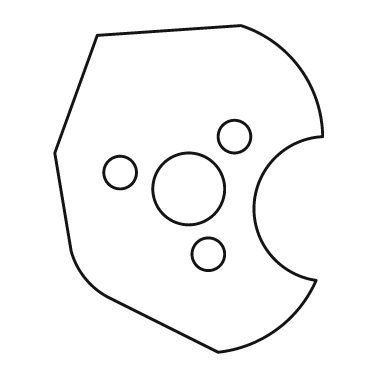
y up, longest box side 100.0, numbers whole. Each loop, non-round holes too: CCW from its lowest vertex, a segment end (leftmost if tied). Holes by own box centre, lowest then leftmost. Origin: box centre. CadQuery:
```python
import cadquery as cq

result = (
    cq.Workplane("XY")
    .moveTo(9.0, -50.0)
    .threePointArc((27.0, -43.0), (39.0, -28.0))
    .threePointArc((20.0, -5.0), (41.0, 16.0))
    .threePointArc((34.0, 37.0), (16.0, 50.0))
    .lineTo(-28.0, 47.0)
    .lineTo(-41.0, 11.0)
    .lineTo(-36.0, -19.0)
    .threePointArc((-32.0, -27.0), (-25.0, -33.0))
    .close()
    .moveTo(6.0, -20.0)
    .circle(5.0)
    .moveTo(0.0, 0.0)
    .circle(11.0)
    .moveTo(-21.0, 5.0)
    .circle(5.0)
    .moveTo(14.0, 16.0)
    .circle(5.0)
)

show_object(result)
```